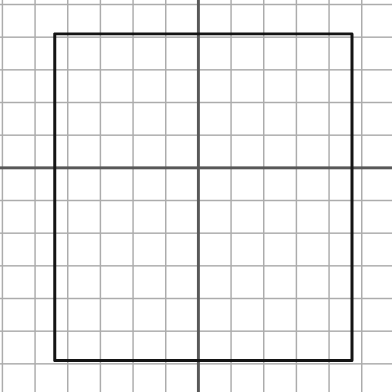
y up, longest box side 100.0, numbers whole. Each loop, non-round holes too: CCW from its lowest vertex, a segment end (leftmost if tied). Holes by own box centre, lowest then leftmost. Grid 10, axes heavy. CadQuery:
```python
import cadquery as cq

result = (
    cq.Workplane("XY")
    .moveTo(-44.0, -59.0)
    .lineTo(47.0, -59.0)
    .lineTo(47.0, 41.0)
    .lineTo(-44.0, 41.0)
    .close()
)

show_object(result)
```